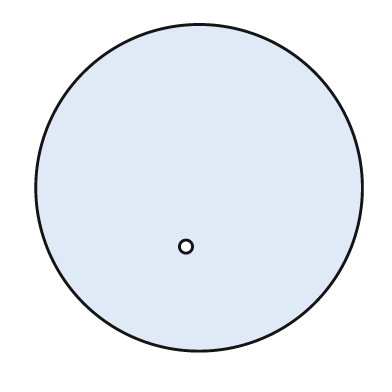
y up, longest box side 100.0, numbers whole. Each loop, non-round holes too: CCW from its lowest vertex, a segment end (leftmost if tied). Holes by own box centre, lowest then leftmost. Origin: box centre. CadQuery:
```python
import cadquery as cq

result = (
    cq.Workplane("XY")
    .moveTo(0.0, 0.0)
    .circle(50.0)
    .moveTo(-4.0, -18.0)
    .circle(2.0)
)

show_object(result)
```